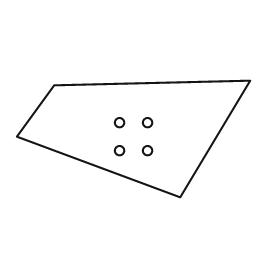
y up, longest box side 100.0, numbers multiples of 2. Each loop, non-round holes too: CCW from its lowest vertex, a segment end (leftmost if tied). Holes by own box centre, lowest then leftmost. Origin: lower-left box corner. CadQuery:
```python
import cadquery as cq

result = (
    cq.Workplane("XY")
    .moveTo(70.0, 0.0)
    .lineTo(100.0, 50.0)
    .lineTo(16.0, 48.0)
    .lineTo(0.0, 26.0)
    .close()
    .moveTo(44.0, 20.0)
    .circle(2.0)
    .moveTo(56.0, 20.0)
    .circle(2.0)
    .moveTo(44.0, 32.0)
    .circle(2.0)
    .moveTo(56.0, 32.0)
    .circle(2.0)
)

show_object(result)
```